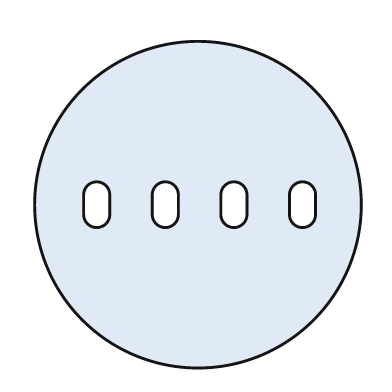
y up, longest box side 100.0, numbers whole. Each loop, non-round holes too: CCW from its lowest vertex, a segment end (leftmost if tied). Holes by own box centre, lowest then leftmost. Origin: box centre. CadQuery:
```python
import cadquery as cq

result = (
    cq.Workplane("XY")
    .moveTo(0.0, 0.0)
    .circle(50.0)
    .moveTo(-35.0, -3.0)
    .threePointArc((-31.0, -7.0), (-27.0, -3.0))
    .lineTo(-27.0, 3.0)
    .threePointArc((-31.0, 7.0), (-35.0, 3.0))
    .close()
    .moveTo(-14.0, -3.0)
    .threePointArc((-10.0, -7.0), (-6.0, -3.0))
    .lineTo(-6.0, 3.0)
    .threePointArc((-10.0, 7.0), (-14.0, 3.0))
    .close()
    .moveTo(7.0, -3.0)
    .threePointArc((11.0, -7.0), (15.0, -3.0))
    .lineTo(15.0, 3.0)
    .threePointArc((11.0, 7.0), (7.0, 3.0))
    .close()
    .moveTo(28.0, -3.0)
    .threePointArc((32.0, -7.0), (36.0, -3.0))
    .lineTo(36.0, 3.0)
    .threePointArc((32.0, 7.0), (28.0, 3.0))
    .close()
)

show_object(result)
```